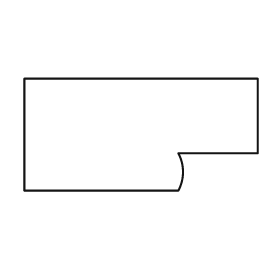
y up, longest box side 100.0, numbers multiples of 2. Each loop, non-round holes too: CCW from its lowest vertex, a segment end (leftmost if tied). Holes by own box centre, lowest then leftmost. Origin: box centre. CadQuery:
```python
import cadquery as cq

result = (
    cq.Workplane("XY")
    .moveTo(-50.0, -24.0)
    .lineTo(16.0, -24.0)
    .threePointArc((18.0, -16.0), (16.0, -8.0))
    .lineTo(50.0, -8.0)
    .lineTo(50.0, 24.0)
    .lineTo(-50.0, 24.0)
    .close()
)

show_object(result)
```